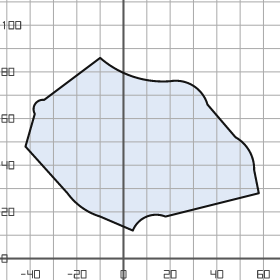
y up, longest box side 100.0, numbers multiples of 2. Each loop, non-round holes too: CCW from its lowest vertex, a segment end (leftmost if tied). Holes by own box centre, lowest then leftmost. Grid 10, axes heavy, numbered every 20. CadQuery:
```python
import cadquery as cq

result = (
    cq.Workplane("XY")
    .moveTo(4.0, 12.0)
    .threePointArc((10.0, 18.0), (18.0, 18.0))
    .lineTo(58.0, 28.0)
    .lineTo(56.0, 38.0)
    .threePointArc((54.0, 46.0), (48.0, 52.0))
    .lineTo(36.0, 66.0)
    .threePointArc((30.0, 74.0), (20.0, 76.0))
    .threePointArc((4.0, 78.0), (-10.0, 86.0))
    .lineTo(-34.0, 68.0)
    .threePointArc((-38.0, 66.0), (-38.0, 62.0))
    .lineTo(-42.0, 48.0)
    .lineTo(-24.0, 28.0)
    .threePointArc((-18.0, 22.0), (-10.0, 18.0))
    .close()
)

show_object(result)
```